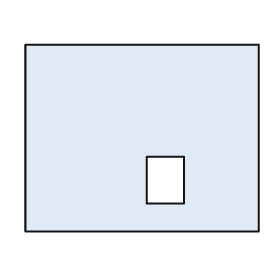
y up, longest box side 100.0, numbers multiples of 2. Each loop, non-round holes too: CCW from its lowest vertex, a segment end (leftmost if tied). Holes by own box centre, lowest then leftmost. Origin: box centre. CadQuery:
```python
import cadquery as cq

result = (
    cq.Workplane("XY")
    .moveTo(-50.0, -40.0)
    .lineTo(50.0, -40.0)
    .lineTo(50.0, 40.0)
    .lineTo(-50.0, 40.0)
    .close()
    .moveTo(2.0, -28.0)
    .lineTo(18.0, -28.0)
    .lineTo(18.0, -8.0)
    .lineTo(2.0, -8.0)
    .close()
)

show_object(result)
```